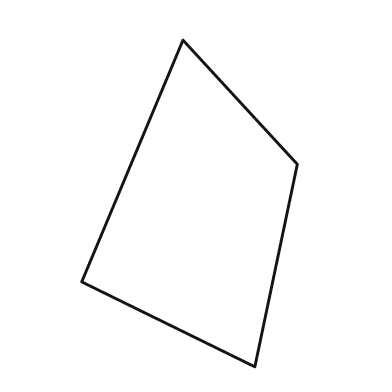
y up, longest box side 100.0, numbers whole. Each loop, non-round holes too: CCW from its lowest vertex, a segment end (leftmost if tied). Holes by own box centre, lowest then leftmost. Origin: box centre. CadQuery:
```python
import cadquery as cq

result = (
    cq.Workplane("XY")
    .moveTo(20.0, -50.0)
    .lineTo(33.0, 12.0)
    .lineTo(-2.0, 50.0)
    .lineTo(-33.0, -24.0)
    .close()
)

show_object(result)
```